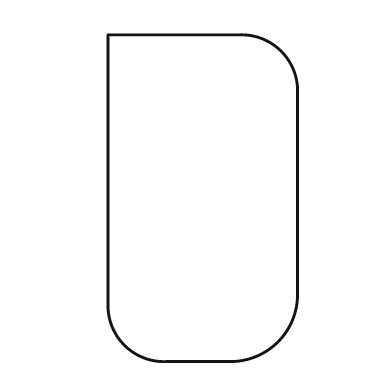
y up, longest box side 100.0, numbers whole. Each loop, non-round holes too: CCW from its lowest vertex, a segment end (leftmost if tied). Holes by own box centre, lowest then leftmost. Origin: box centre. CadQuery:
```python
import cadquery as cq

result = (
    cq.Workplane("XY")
    .moveTo(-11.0, -50.0)
    .lineTo(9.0, -50.0)
    .threePointArc((23.0, -44.0), (29.0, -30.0))
    .lineTo(29.0, 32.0)
    .threePointArc((24.0, 45.0), (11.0, 50.0))
    .lineTo(-29.0, 50.0)
    .lineTo(-29.0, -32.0)
    .threePointArc((-24.0, -45.0), (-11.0, -50.0))
    .close()
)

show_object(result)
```